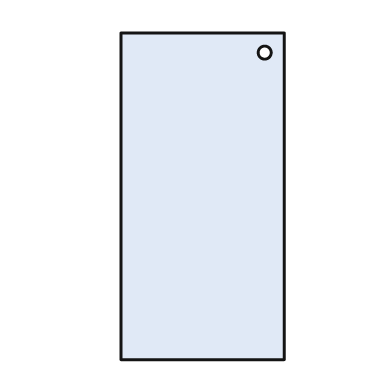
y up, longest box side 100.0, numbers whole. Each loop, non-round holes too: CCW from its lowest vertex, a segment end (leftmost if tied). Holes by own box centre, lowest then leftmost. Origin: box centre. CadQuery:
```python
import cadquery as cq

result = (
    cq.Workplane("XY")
    .moveTo(-25.0, -50.0)
    .lineTo(25.0, -50.0)
    .lineTo(25.0, 50.0)
    .lineTo(-25.0, 50.0)
    .close()
    .moveTo(19.0, 44.0)
    .circle(2.0)
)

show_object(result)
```